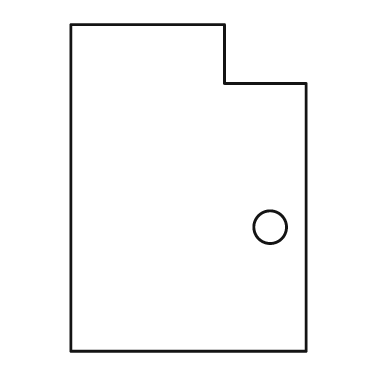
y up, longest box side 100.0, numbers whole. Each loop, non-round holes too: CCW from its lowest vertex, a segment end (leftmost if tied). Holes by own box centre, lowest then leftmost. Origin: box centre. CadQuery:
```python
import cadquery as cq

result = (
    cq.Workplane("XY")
    .moveTo(-36.0, -50.0)
    .lineTo(36.0, -50.0)
    .lineTo(36.0, 32.0)
    .lineTo(11.0, 32.0)
    .lineTo(11.0, 50.0)
    .lineTo(-36.0, 50.0)
    .close()
    .moveTo(25.0, -12.0)
    .circle(5.0)
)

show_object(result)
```